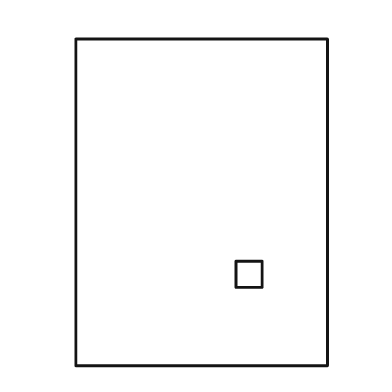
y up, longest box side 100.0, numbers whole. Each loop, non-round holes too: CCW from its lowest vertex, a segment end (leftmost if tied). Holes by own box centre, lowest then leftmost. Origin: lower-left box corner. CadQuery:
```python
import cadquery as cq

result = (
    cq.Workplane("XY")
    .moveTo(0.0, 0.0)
    .lineTo(77.0, 0.0)
    .lineTo(77.0, 100.0)
    .lineTo(0.0, 100.0)
    .close()
    .moveTo(49.0, 24.0)
    .lineTo(57.0, 24.0)
    .lineTo(57.0, 32.0)
    .lineTo(49.0, 32.0)
    .close()
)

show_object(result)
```